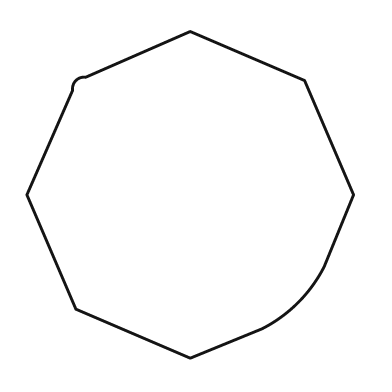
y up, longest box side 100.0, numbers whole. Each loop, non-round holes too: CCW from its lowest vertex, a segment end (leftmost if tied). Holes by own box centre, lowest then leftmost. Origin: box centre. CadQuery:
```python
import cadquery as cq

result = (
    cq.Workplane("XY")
    .moveTo(0.0, -50.0)
    .lineTo(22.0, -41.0)
    .threePointArc((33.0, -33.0), (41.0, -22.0))
    .lineTo(50.0, 0.0)
    .lineTo(35.0, 35.0)
    .lineTo(0.0, 50.0)
    .lineTo(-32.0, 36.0)
    .threePointArc((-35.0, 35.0), (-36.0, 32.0))
    .lineTo(-50.0, 0.0)
    .lineTo(-35.0, -35.0)
    .close()
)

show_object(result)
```